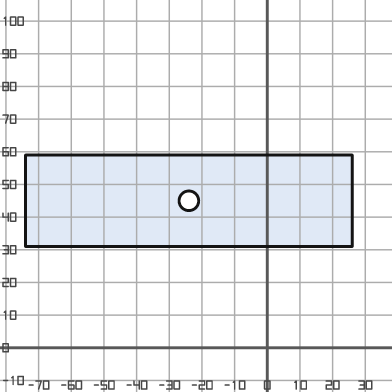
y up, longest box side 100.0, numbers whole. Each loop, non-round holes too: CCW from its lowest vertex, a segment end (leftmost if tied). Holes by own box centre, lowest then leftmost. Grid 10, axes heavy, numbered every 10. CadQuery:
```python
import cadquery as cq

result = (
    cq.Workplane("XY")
    .moveTo(-74.0, 31.0)
    .lineTo(26.0, 31.0)
    .lineTo(26.0, 59.0)
    .lineTo(-74.0, 59.0)
    .close()
    .moveTo(-24.0, 45.0)
    .circle(3.0)
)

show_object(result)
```